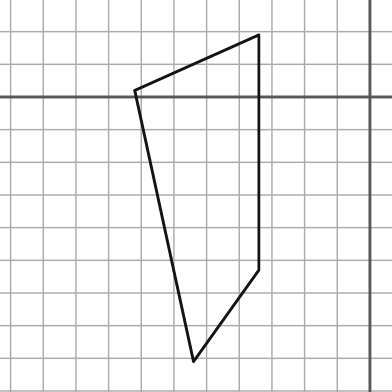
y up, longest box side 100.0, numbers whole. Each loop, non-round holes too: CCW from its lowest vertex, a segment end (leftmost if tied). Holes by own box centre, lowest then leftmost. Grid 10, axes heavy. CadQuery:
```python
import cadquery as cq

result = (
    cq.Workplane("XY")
    .moveTo(-54.0, -81.0)
    .lineTo(-34.0, -53.0)
    .lineTo(-34.0, 19.0)
    .lineTo(-72.0, 2.0)
    .close()
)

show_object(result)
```